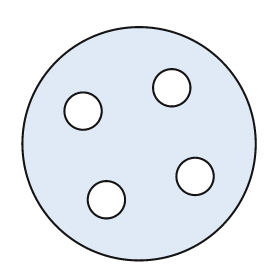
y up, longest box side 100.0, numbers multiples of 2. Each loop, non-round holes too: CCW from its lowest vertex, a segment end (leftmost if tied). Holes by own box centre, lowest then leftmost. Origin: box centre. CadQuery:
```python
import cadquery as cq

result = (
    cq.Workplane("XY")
    .moveTo(0.0, 0.0)
    .circle(50.0)
    .moveTo(-14.0, -24.0)
    .circle(8.0)
    .moveTo(24.0, -14.0)
    .circle(8.0)
    .moveTo(-24.0, 14.0)
    .circle(8.0)
    .moveTo(14.0, 24.0)
    .circle(8.0)
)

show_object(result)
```